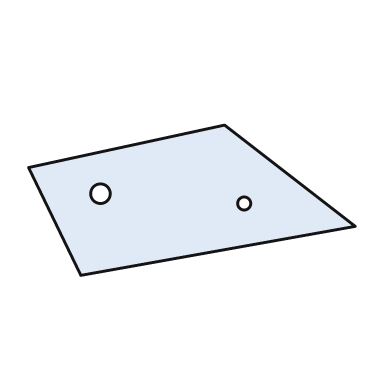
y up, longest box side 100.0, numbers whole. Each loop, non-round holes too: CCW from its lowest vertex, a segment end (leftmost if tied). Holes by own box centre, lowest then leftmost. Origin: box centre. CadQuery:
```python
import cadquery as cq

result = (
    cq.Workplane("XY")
    .moveTo(-34.0, -23.0)
    .lineTo(50.0, -8.0)
    .lineTo(10.0, 23.0)
    .lineTo(-50.0, 10.0)
    .close()
    .moveTo(16.0, -1.0)
    .circle(2.0)
    .moveTo(-28.0, 2.0)
    .circle(3.0)
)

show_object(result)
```